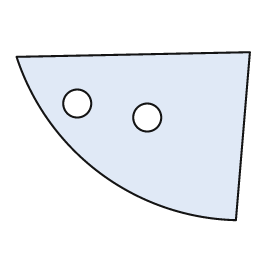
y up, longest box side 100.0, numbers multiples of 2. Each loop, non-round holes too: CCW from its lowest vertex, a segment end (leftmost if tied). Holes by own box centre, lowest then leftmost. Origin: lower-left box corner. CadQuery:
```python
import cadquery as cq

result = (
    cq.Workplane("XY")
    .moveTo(94.0, 0.0)
    .lineTo(100.0, 72.0)
    .lineTo(0.0, 70.0)
    .threePointArc((36.0, 20.0), (94.0, 0.0))
    .close()
    .moveTo(56.0, 44.0)
    .circle(6.0)
    .moveTo(26.0, 50.0)
    .circle(6.0)
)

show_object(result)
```